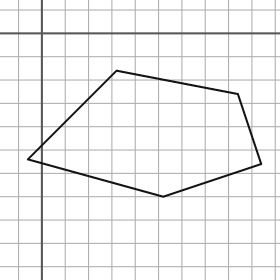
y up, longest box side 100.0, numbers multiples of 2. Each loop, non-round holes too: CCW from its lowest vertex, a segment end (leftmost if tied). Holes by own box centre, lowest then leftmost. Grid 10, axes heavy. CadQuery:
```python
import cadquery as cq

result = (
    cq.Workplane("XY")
    .moveTo(52.0, -70.0)
    .lineTo(94.0, -56.0)
    .lineTo(84.0, -26.0)
    .lineTo(32.0, -16.0)
    .lineTo(-6.0, -54.0)
    .close()
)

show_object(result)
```